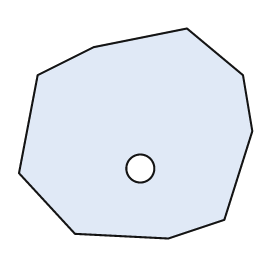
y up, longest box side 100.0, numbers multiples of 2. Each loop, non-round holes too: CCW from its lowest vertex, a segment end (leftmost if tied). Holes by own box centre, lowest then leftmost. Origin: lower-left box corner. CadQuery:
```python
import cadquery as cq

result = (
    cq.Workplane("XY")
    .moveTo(64.0, 0.0)
    .lineTo(88.0, 8.0)
    .lineTo(100.0, 46.0)
    .lineTo(96.0, 70.0)
    .lineTo(72.0, 90.0)
    .lineTo(32.0, 82.0)
    .lineTo(8.0, 70.0)
    .lineTo(0.0, 28.0)
    .lineTo(24.0, 2.0)
    .close()
    .moveTo(52.0, 30.0)
    .circle(6.0)
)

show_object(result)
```